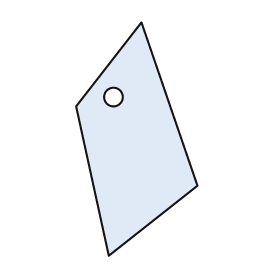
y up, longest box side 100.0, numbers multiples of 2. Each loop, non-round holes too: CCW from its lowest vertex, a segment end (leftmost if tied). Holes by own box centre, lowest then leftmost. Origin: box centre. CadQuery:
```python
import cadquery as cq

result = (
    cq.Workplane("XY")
    .moveTo(-12.0, -50.0)
    .lineTo(26.0, -20.0)
    .lineTo(2.0, 50.0)
    .lineTo(-26.0, 14.0)
    .close()
    .moveTo(-10.0, 18.0)
    .circle(4.0)
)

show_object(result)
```